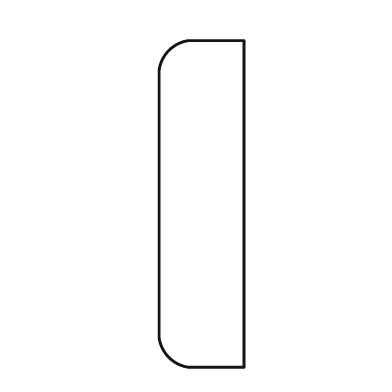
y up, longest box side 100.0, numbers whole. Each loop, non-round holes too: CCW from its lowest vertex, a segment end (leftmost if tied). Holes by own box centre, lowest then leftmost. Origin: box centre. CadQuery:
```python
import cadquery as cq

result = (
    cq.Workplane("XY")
    .moveTo(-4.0, -50.0)
    .lineTo(13.0, -50.0)
    .lineTo(13.0, 50.0)
    .lineTo(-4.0, 50.0)
    .threePointArc((-10.0, 47.0), (-13.0, 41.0))
    .lineTo(-13.0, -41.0)
    .threePointArc((-10.0, -47.0), (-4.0, -50.0))
    .close()
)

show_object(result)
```